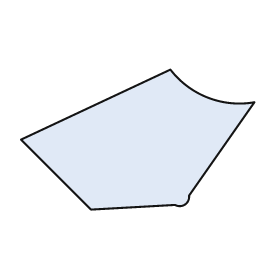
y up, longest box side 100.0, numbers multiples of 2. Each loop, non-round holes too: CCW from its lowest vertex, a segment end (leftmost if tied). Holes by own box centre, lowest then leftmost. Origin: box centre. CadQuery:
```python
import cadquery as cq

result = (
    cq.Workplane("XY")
    .moveTo(-20.0, -30.0)
    .lineTo(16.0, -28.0)
    .threePointArc((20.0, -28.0), (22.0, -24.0))
    .lineTo(50.0, 16.0)
    .threePointArc((30.0, 18.0), (14.0, 30.0))
    .lineTo(-50.0, 0.0)
    .close()
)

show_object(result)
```